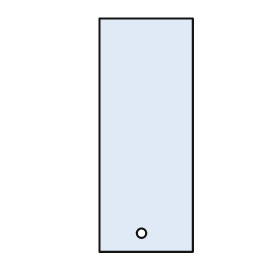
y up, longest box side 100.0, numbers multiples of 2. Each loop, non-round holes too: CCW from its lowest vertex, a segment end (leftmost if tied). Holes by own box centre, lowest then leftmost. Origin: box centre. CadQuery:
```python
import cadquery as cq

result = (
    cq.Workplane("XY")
    .moveTo(-20.0, -50.0)
    .lineTo(20.0, -50.0)
    .lineTo(20.0, 50.0)
    .lineTo(-20.0, 50.0)
    .close()
    .moveTo(-2.0, -42.0)
    .circle(2.0)
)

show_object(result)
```